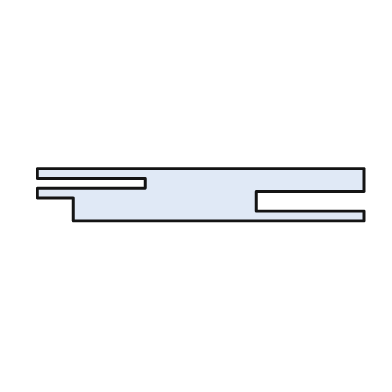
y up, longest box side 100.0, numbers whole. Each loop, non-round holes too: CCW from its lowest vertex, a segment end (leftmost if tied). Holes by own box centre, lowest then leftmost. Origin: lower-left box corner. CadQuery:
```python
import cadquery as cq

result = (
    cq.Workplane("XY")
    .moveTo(11.0, 0.0)
    .lineTo(100.0, 0.0)
    .lineTo(100.0, 3.0)
    .lineTo(67.0, 3.0)
    .lineTo(67.0, 9.0)
    .lineTo(100.0, 9.0)
    .lineTo(100.0, 16.0)
    .lineTo(0.0, 16.0)
    .lineTo(0.0, 13.0)
    .lineTo(33.0, 13.0)
    .lineTo(33.0, 10.0)
    .lineTo(0.0, 10.0)
    .lineTo(0.0, 7.0)
    .lineTo(11.0, 7.0)
    .close()
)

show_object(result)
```